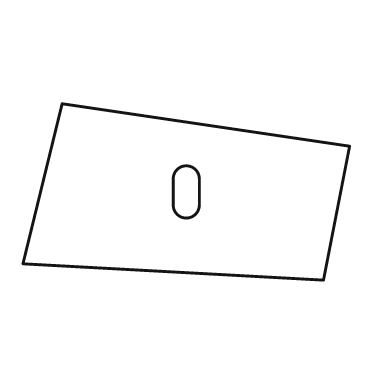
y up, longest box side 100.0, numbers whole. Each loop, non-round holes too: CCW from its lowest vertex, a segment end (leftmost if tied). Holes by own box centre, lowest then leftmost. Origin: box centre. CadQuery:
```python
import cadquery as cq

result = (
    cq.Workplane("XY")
    .moveTo(42.0, -27.0)
    .lineTo(50.0, 14.0)
    .lineTo(-38.0, 27.0)
    .lineTo(-50.0, -22.0)
    .close()
    .moveTo(-4.0, -4.0)
    .threePointArc((0.0, -8.0), (4.0, -4.0))
    .lineTo(4.0, 4.0)
    .threePointArc((0.0, 8.0), (-4.0, 4.0))
    .close()
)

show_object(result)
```